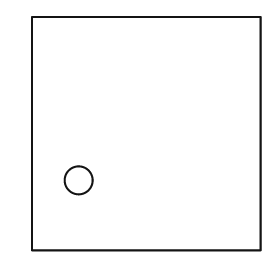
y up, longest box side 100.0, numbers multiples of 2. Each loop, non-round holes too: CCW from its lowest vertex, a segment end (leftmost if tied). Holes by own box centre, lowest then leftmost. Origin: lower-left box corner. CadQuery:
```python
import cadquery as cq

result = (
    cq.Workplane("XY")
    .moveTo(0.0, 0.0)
    .lineTo(98.0, 0.0)
    .lineTo(98.0, 100.0)
    .lineTo(0.0, 100.0)
    .close()
    .moveTo(20.0, 30.0)
    .circle(6.0)
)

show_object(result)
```